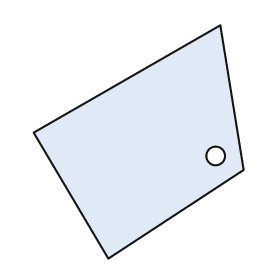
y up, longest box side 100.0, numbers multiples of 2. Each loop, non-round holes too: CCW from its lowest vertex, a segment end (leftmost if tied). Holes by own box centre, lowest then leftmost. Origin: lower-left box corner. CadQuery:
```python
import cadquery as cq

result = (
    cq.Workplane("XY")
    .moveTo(32.0, 0.0)
    .lineTo(90.0, 38.0)
    .lineTo(80.0, 100.0)
    .lineTo(0.0, 54.0)
    .close()
    .moveTo(78.0, 44.0)
    .circle(4.0)
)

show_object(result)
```